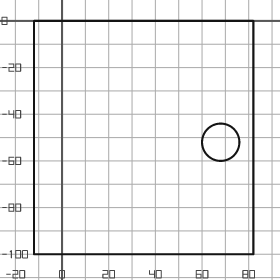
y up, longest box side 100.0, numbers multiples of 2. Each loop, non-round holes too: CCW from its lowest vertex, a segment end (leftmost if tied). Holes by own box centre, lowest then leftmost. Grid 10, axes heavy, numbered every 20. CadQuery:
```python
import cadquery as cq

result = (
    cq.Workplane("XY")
    .moveTo(-12.0, -100.0)
    .lineTo(82.0, -100.0)
    .lineTo(82.0, 0.0)
    .lineTo(-12.0, 0.0)
    .close()
    .moveTo(68.0, -52.0)
    .circle(8.0)
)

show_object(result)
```